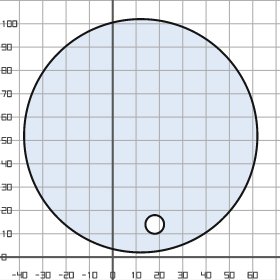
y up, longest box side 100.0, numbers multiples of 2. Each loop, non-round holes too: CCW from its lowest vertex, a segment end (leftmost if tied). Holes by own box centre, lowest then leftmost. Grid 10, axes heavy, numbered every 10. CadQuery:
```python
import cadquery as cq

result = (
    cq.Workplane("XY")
    .moveTo(12.0, 52.0)
    .circle(50.0)
    .moveTo(18.0, 14.0)
    .circle(4.0)
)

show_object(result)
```